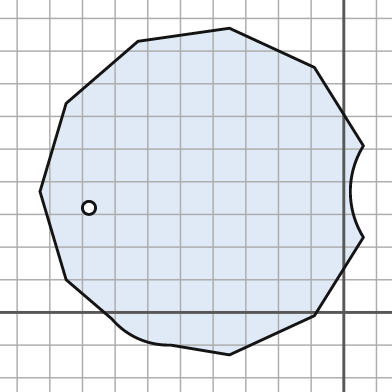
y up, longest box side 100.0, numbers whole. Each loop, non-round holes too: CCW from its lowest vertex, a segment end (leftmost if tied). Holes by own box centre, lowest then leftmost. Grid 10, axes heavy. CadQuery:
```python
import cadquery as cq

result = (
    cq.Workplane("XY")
    .moveTo(-35.0, -13.0)
    .lineTo(-9.0, -1.0)
    .lineTo(6.0, 23.0)
    .threePointArc((2.0, 37.0), (6.0, 51.0))
    .lineTo(-9.0, 75.0)
    .lineTo(-35.0, 87.0)
    .lineTo(-63.0, 83.0)
    .lineTo(-85.0, 64.0)
    .lineTo(-93.0, 37.0)
    .lineTo(-85.0, 10.0)
    .lineTo(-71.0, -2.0)
    .threePointArc((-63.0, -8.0), (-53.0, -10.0))
    .close()
    .moveTo(-78.0, 32.0)
    .circle(2.0)
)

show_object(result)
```